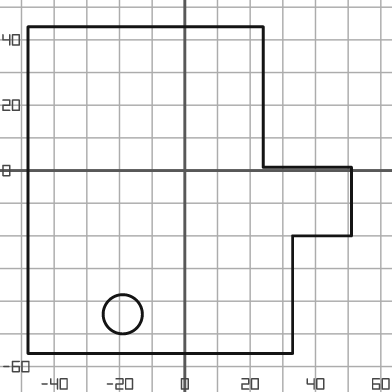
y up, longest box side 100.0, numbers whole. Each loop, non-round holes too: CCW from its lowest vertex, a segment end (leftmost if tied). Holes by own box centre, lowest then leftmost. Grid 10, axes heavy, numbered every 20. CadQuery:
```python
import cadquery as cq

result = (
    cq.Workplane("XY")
    .moveTo(-48.0, -56.0)
    .lineTo(33.0, -56.0)
    .lineTo(33.0, -20.0)
    .lineTo(51.0, -20.0)
    .lineTo(51.0, 1.0)
    .lineTo(24.0, 1.0)
    .lineTo(24.0, 44.0)
    .lineTo(-48.0, 44.0)
    .close()
    .moveTo(-19.0, -44.0)
    .circle(6.0)
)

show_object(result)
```